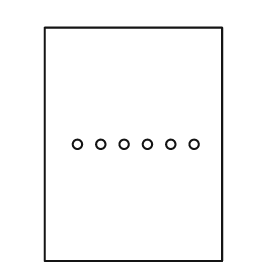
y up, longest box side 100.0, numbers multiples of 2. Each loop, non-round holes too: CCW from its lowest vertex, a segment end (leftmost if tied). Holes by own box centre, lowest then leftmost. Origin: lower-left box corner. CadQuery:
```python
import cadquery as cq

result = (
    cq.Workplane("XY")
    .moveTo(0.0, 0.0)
    .lineTo(76.0, 0.0)
    .lineTo(76.0, 100.0)
    .lineTo(0.0, 100.0)
    .close()
    .moveTo(14.0, 50.0)
    .circle(2.0)
    .moveTo(24.0, 50.0)
    .circle(2.0)
    .moveTo(34.0, 50.0)
    .circle(2.0)
    .moveTo(44.0, 50.0)
    .circle(2.0)
    .moveTo(54.0, 50.0)
    .circle(2.0)
    .moveTo(64.0, 50.0)
    .circle(2.0)
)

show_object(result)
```